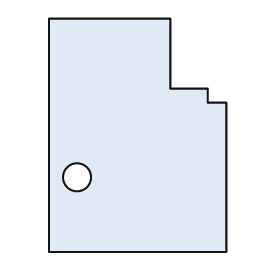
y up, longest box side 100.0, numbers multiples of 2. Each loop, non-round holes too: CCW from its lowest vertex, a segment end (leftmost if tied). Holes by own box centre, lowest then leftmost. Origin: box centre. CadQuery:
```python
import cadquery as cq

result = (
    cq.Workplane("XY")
    .moveTo(-38.0, -50.0)
    .lineTo(38.0, -50.0)
    .lineTo(38.0, 14.0)
    .lineTo(30.0, 14.0)
    .lineTo(30.0, 20.0)
    .lineTo(14.0, 20.0)
    .lineTo(14.0, 50.0)
    .lineTo(-38.0, 50.0)
    .close()
    .moveTo(-26.0, -18.0)
    .circle(6.0)
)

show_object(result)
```